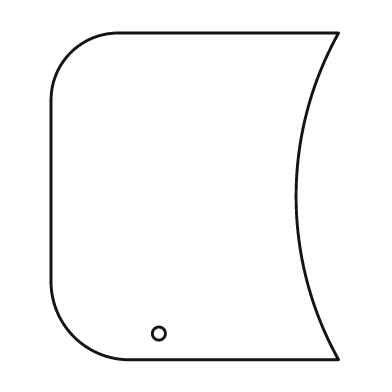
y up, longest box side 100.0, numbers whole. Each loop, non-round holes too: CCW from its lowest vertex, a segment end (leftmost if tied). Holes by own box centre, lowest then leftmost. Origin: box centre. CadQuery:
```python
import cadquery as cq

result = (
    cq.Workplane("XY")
    .moveTo(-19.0, -50.0)
    .lineTo(44.0, -50.0)
    .threePointArc((31.0, 0.0), (44.0, 50.0))
    .lineTo(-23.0, 50.0)
    .threePointArc((-38.0, 44.0), (-44.0, 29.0))
    .lineTo(-44.0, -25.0)
    .threePointArc((-37.0, -43.0), (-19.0, -50.0))
    .close()
    .moveTo(-11.0, -42.0)
    .circle(2.0)
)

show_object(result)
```